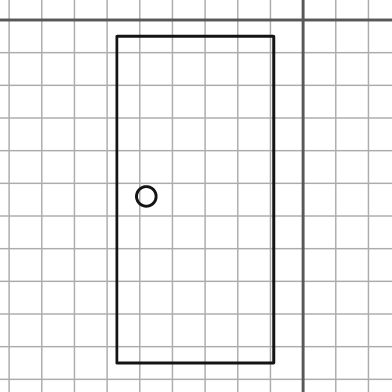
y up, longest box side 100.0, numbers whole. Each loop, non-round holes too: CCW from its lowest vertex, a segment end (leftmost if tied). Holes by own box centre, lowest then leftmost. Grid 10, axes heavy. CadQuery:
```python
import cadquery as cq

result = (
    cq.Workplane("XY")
    .moveTo(-57.0, -105.0)
    .lineTo(-9.0, -105.0)
    .lineTo(-9.0, -5.0)
    .lineTo(-57.0, -5.0)
    .close()
    .moveTo(-48.0, -54.0)
    .circle(3.0)
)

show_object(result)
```